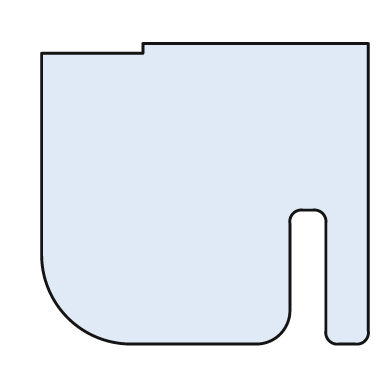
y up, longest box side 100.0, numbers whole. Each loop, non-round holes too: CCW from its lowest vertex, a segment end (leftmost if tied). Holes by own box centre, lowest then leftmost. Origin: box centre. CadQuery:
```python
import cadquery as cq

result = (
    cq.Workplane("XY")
    .moveTo(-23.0, -46.0)
    .lineTo(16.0, -46.0)
    .threePointArc((23.0, -43.0), (26.0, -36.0))
    .lineTo(26.0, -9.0)
    .threePointArc((27.0, -6.0), (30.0, -5.0))
    .lineTo(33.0, -5.0)
    .threePointArc((36.0, -6.0), (37.0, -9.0))
    .lineTo(37.0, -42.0)
    .threePointArc((38.0, -45.0), (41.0, -46.0))
    .lineTo(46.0, -46.0)
    .threePointArc((49.0, -45.0), (50.0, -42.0))
    .lineTo(50.0, 46.0)
    .lineTo(-19.0, 46.0)
    .lineTo(-19.0, 43.0)
    .lineTo(-50.0, 43.0)
    .lineTo(-50.0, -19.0)
    .threePointArc((-42.0, -38.0), (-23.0, -46.0))
    .close()
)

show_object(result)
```